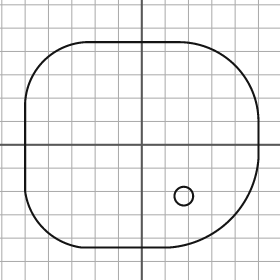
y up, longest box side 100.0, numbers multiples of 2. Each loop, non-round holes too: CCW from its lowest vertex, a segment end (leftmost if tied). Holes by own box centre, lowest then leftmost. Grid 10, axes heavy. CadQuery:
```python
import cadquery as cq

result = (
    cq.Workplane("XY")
    .moveTo(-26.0, -44.0)
    .lineTo(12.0, -44.0)
    .threePointArc((38.0, -32.0), (50.0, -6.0))
    .lineTo(50.0, 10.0)
    .threePointArc((40.0, 34.0), (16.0, 44.0))
    .lineTo(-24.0, 44.0)
    .threePointArc((-42.0, 36.0), (-50.0, 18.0))
    .lineTo(-50.0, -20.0)
    .threePointArc((-42.0, -36.0), (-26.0, -44.0))
    .close()
    .moveTo(18.0, -22.0)
    .circle(4.0)
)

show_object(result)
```